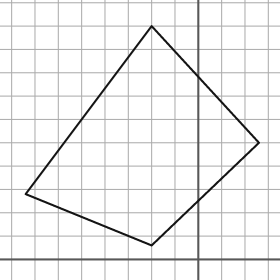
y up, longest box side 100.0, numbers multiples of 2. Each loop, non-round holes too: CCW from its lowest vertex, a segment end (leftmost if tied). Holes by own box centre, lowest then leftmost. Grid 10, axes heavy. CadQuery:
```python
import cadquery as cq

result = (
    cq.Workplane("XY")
    .moveTo(-20.0, 6.0)
    .lineTo(26.0, 50.0)
    .lineTo(-20.0, 100.0)
    .lineTo(-74.0, 28.0)
    .close()
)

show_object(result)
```